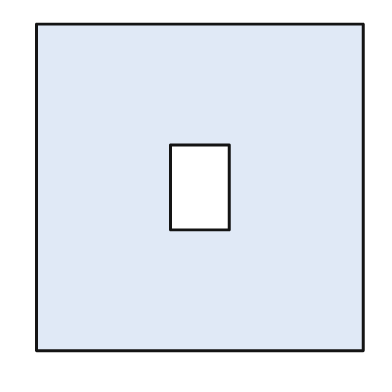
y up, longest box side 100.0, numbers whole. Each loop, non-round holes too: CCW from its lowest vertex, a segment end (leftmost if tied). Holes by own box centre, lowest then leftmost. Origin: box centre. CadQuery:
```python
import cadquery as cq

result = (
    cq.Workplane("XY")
    .moveTo(-50.0, -50.0)
    .lineTo(50.0, -50.0)
    .lineTo(50.0, 50.0)
    .lineTo(-50.0, 50.0)
    .close()
    .moveTo(-9.0, -13.0)
    .lineTo(9.0, -13.0)
    .lineTo(9.0, 13.0)
    .lineTo(-9.0, 13.0)
    .close()
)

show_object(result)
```